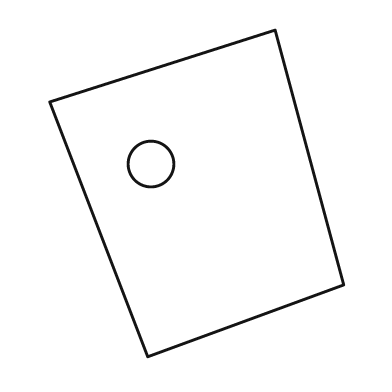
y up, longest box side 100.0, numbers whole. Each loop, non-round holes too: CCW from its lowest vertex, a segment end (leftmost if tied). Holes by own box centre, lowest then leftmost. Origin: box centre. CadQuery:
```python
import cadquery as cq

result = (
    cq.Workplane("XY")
    .moveTo(-15.0, -50.0)
    .lineTo(45.0, -28.0)
    .lineTo(24.0, 50.0)
    .lineTo(-45.0, 28.0)
    .close()
    .moveTo(-14.0, 9.0)
    .circle(7.0)
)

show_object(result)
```